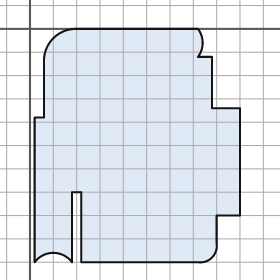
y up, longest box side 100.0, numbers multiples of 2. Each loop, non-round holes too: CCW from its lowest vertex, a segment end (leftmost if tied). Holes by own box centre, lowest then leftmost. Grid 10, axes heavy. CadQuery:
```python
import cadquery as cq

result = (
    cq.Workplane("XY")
    .moveTo(2.0, -100.0)
    .threePointArc((10.0, -96.0), (18.0, -100.0))
    .lineTo(18.0, -70.0)
    .lineTo(22.0, -70.0)
    .lineTo(22.0, -100.0)
    .lineTo(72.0, -100.0)
    .threePointArc((78.0, -98.0), (80.0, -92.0))
    .lineTo(80.0, -80.0)
    .lineTo(90.0, -80.0)
    .lineTo(90.0, -34.0)
    .lineTo(78.0, -34.0)
    .lineTo(78.0, -12.0)
    .lineTo(72.0, -12.0)
    .threePointArc((74.0, -6.0), (72.0, 0.0))
    .lineTo(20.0, 0.0)
    .threePointArc((10.0, -4.0), (6.0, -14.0))
    .lineTo(6.0, -38.0)
    .lineTo(2.0, -38.0)
    .close()
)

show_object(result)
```